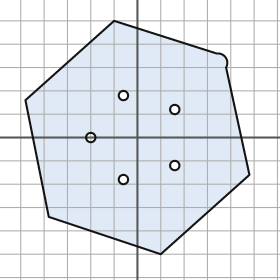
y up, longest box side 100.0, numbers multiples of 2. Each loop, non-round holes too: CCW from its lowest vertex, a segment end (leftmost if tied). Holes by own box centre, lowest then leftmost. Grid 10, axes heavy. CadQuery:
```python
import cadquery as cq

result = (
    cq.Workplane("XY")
    .moveTo(10.0, -50.0)
    .lineTo(48.0, -16.0)
    .lineTo(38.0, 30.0)
    .threePointArc((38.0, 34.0), (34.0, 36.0))
    .lineTo(-10.0, 50.0)
    .lineTo(-48.0, 16.0)
    .lineTo(-38.0, -34.0)
    .close()
    .moveTo(-6.0, -18.0)
    .circle(2.0)
    .moveTo(16.0, -12.0)
    .circle(2.0)
    .moveTo(-20.0, 0.0)
    .circle(2.0)
    .moveTo(16.0, 12.0)
    .circle(2.0)
    .moveTo(-6.0, 18.0)
    .circle(2.0)
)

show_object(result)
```